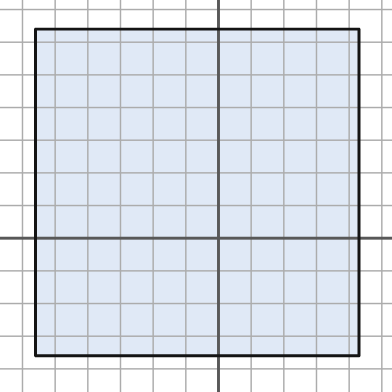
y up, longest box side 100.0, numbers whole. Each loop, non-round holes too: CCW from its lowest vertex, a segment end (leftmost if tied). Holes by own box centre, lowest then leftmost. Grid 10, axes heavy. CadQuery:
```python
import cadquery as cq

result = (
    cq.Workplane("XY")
    .moveTo(-56.0, -36.0)
    .lineTo(43.0, -36.0)
    .lineTo(43.0, 64.0)
    .lineTo(-56.0, 64.0)
    .close()
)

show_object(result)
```